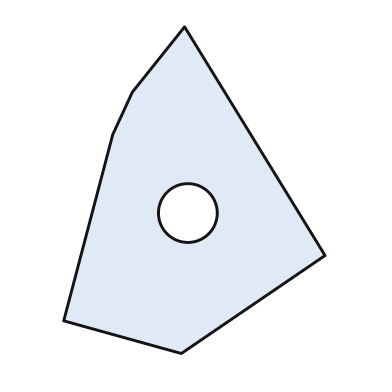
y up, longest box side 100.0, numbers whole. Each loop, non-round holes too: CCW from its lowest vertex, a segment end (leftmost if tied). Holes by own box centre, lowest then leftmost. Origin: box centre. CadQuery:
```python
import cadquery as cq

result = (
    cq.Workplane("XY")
    .moveTo(-4.0, -50.0)
    .lineTo(40.0, -20.0)
    .lineTo(-3.0, 50.0)
    .lineTo(-19.0, 30.0)
    .lineTo(-25.0, 17.0)
    .lineTo(-40.0, -40.0)
    .close()
    .moveTo(-2.0, -7.0)
    .circle(9.0)
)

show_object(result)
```